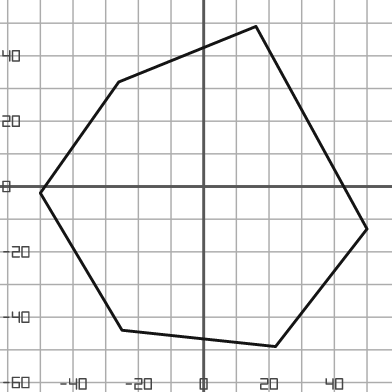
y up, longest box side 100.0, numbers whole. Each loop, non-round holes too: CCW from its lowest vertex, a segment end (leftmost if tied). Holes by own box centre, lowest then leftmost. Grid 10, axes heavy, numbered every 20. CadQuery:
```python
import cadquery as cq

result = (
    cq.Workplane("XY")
    .moveTo(22.0, -49.0)
    .lineTo(50.0, -13.0)
    .lineTo(16.0, 49.0)
    .lineTo(-26.0, 32.0)
    .lineTo(-50.0, -2.0)
    .lineTo(-25.0, -44.0)
    .close()
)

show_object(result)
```